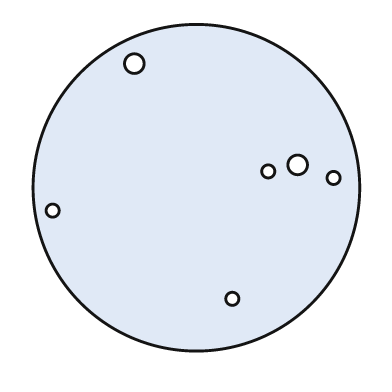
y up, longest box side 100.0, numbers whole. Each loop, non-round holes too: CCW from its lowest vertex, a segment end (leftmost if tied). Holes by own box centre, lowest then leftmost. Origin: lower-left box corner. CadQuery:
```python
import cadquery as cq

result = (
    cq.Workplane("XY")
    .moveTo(50.0, 50.0)
    .circle(50.0)
    .moveTo(61.0, 16.0)
    .circle(2.0)
    .moveTo(6.0, 43.0)
    .circle(2.0)
    .moveTo(92.0, 53.0)
    .circle(2.0)
    .moveTo(72.0, 55.0)
    .circle(2.0)
    .moveTo(81.0, 57.0)
    .circle(3.0)
    .moveTo(31.0, 88.0)
    .circle(3.0)
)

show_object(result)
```